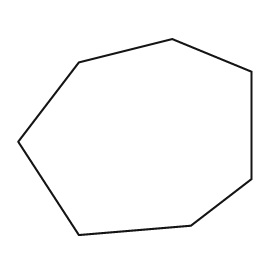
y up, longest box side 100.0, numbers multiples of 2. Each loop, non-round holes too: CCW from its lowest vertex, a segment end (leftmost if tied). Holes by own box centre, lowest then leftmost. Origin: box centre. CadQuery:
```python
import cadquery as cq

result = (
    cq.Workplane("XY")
    .moveTo(-24.0, -42.0)
    .lineTo(24.0, -38.0)
    .lineTo(50.0, -18.0)
    .lineTo(50.0, 28.0)
    .lineTo(16.0, 42.0)
    .lineTo(-24.0, 32.0)
    .lineTo(-50.0, -2.0)
    .close()
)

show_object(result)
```